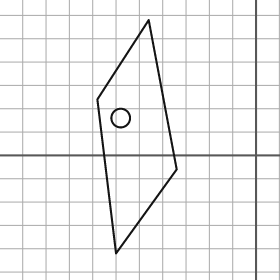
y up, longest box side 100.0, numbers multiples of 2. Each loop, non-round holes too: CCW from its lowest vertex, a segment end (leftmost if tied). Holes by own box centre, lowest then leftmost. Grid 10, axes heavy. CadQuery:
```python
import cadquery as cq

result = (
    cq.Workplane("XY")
    .moveTo(-60.0, -42.0)
    .lineTo(-34.0, -6.0)
    .lineTo(-46.0, 58.0)
    .lineTo(-68.0, 24.0)
    .close()
    .moveTo(-58.0, 16.0)
    .circle(4.0)
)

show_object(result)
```